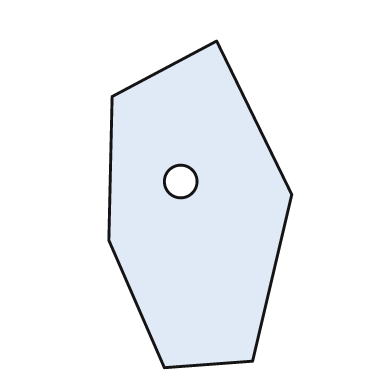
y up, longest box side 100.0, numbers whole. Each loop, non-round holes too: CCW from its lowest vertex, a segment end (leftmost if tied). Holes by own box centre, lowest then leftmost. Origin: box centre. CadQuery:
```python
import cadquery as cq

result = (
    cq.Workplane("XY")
    .moveTo(-11.0, -50.0)
    .lineTo(16.0, -48.0)
    .lineTo(28.0, 3.0)
    .lineTo(5.0, 50.0)
    .lineTo(-27.0, 33.0)
    .lineTo(-28.0, -11.0)
    .close()
    .moveTo(-6.0, 7.0)
    .circle(5.0)
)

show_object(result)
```